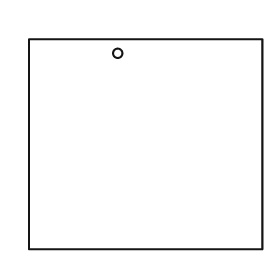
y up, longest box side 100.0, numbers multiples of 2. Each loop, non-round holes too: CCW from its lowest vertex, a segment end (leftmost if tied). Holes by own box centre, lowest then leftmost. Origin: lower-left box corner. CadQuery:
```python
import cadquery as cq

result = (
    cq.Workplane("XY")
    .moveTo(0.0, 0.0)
    .lineTo(100.0, 0.0)
    .lineTo(100.0, 90.0)
    .lineTo(0.0, 90.0)
    .close()
    .moveTo(38.0, 84.0)
    .circle(2.0)
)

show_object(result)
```